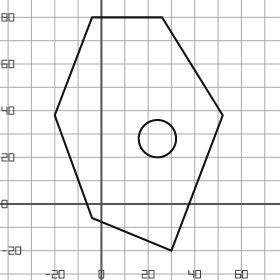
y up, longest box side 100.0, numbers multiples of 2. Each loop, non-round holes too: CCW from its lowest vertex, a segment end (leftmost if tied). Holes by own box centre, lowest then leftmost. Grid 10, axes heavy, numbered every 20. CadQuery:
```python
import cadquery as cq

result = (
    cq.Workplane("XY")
    .moveTo(30.0, -20.0)
    .lineTo(52.0, 38.0)
    .lineTo(26.0, 80.0)
    .lineTo(-4.0, 80.0)
    .lineTo(-20.0, 38.0)
    .lineTo(-4.0, -6.0)
    .close()
    .moveTo(24.0, 28.0)
    .circle(8.0)
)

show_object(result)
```